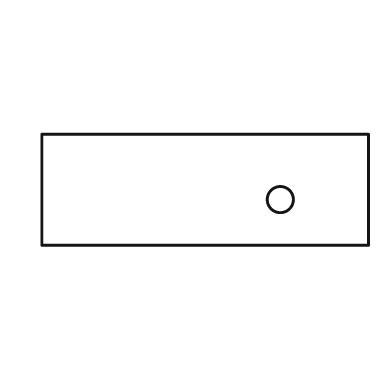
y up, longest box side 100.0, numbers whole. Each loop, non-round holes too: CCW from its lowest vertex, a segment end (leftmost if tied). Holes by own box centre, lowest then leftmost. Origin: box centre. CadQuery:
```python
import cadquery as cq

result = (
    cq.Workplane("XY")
    .moveTo(-50.0, -17.0)
    .lineTo(50.0, -17.0)
    .lineTo(50.0, 17.0)
    .lineTo(-50.0, 17.0)
    .close()
    .moveTo(23.0, -3.0)
    .circle(4.0)
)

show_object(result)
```